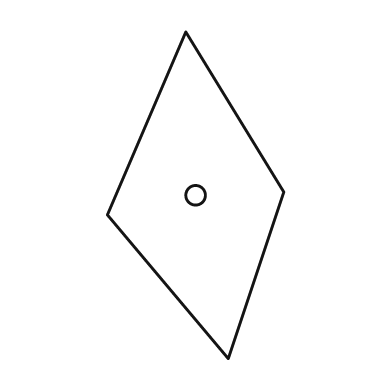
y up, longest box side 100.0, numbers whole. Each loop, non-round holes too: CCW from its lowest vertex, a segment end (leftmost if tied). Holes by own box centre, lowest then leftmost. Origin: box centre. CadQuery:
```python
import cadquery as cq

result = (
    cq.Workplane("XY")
    .moveTo(10.0, -50.0)
    .lineTo(27.0, 1.0)
    .lineTo(-3.0, 50.0)
    .lineTo(-27.0, -6.0)
    .close()
    .moveTo(0.0, 0.0)
    .circle(3.0)
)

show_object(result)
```